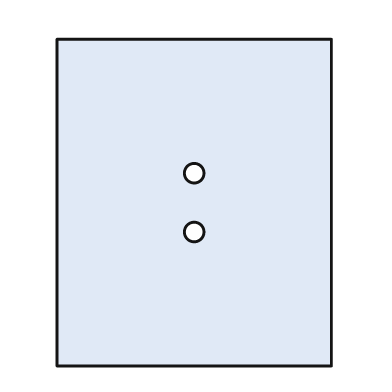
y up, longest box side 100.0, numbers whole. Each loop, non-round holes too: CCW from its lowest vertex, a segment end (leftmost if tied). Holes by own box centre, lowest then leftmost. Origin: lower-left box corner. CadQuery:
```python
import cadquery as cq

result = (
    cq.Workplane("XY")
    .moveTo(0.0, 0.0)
    .lineTo(84.0, 0.0)
    .lineTo(84.0, 100.0)
    .lineTo(0.0, 100.0)
    .close()
    .moveTo(42.0, 41.0)
    .circle(3.0)
    .moveTo(42.0, 59.0)
    .circle(3.0)
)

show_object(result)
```